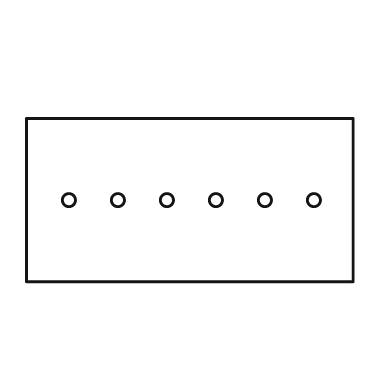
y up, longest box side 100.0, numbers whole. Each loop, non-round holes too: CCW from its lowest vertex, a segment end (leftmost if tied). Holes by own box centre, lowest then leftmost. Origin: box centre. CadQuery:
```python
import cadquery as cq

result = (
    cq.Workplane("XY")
    .moveTo(-50.0, -25.0)
    .lineTo(50.0, -25.0)
    .lineTo(50.0, 25.0)
    .lineTo(-50.0, 25.0)
    .close()
    .moveTo(-37.0, 0.0)
    .circle(2.0)
    .moveTo(-22.0, 0.0)
    .circle(2.0)
    .moveTo(-7.0, 0.0)
    .circle(2.0)
    .moveTo(8.0, 0.0)
    .circle(2.0)
    .moveTo(23.0, 0.0)
    .circle(2.0)
    .moveTo(38.0, 0.0)
    .circle(2.0)
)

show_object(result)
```